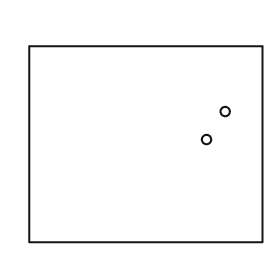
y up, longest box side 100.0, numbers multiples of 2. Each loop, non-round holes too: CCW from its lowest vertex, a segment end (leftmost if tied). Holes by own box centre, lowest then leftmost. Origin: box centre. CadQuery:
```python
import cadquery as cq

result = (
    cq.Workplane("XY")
    .moveTo(-50.0, -42.0)
    .lineTo(50.0, -42.0)
    .lineTo(50.0, 42.0)
    .lineTo(-50.0, 42.0)
    .close()
    .moveTo(26.0, 2.0)
    .circle(2.0)
    .moveTo(34.0, 14.0)
    .circle(2.0)
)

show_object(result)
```